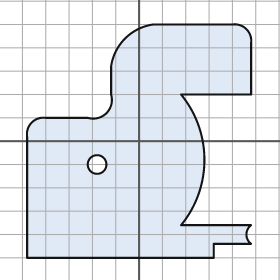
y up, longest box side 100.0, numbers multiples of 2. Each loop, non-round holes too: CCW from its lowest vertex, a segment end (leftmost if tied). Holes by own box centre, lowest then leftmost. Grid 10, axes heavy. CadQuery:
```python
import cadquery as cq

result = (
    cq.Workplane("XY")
    .moveTo(-48.0, -50.0)
    .lineTo(32.0, -50.0)
    .lineTo(32.0, -44.0)
    .lineTo(48.0, -44.0)
    .threePointArc((46.0, -40.0), (48.0, -36.0))
    .lineTo(18.0, -36.0)
    .threePointArc((28.0, -8.0), (18.0, 20.0))
    .lineTo(48.0, 20.0)
    .lineTo(48.0, 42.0)
    .threePointArc((46.0, 48.0), (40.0, 50.0))
    .lineTo(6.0, 50.0)
    .threePointArc((-6.0, 44.0), (-12.0, 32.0))
    .lineTo(-12.0, 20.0)
    .threePointArc((-14.0, 12.0), (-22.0, 10.0))
    .lineTo(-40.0, 10.0)
    .threePointArc((-46.0, 8.0), (-48.0, 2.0))
    .close()
    .moveTo(-18.0, -10.0)
    .circle(4.0)
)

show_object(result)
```